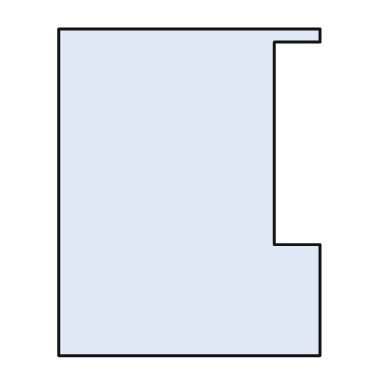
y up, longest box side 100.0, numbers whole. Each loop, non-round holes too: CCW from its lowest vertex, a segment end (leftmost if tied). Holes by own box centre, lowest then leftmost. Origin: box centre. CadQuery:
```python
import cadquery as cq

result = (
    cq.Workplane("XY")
    .moveTo(-40.0, -50.0)
    .lineTo(40.0, -50.0)
    .lineTo(40.0, -16.0)
    .lineTo(26.0, -16.0)
    .lineTo(26.0, 46.0)
    .lineTo(40.0, 46.0)
    .lineTo(40.0, 50.0)
    .lineTo(-40.0, 50.0)
    .close()
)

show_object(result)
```